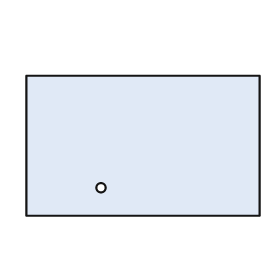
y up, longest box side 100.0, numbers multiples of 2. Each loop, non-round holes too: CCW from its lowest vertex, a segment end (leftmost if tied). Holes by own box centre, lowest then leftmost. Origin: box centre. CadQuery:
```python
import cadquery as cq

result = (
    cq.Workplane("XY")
    .moveTo(-50.0, -30.0)
    .lineTo(50.0, -30.0)
    .lineTo(50.0, 30.0)
    .lineTo(-50.0, 30.0)
    .close()
    .moveTo(-18.0, -18.0)
    .circle(2.0)
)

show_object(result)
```